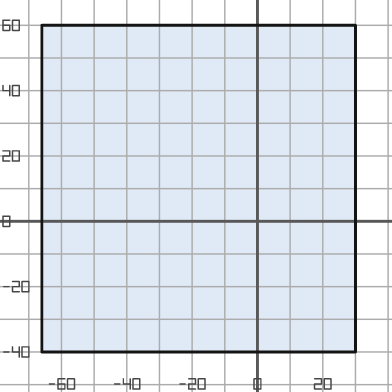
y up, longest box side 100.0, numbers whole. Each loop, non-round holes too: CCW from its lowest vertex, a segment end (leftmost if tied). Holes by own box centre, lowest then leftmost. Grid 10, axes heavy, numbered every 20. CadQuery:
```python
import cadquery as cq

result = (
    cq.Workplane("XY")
    .moveTo(-66.0, -40.0)
    .lineTo(30.0, -40.0)
    .lineTo(30.0, 60.0)
    .lineTo(-66.0, 60.0)
    .close()
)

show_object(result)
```